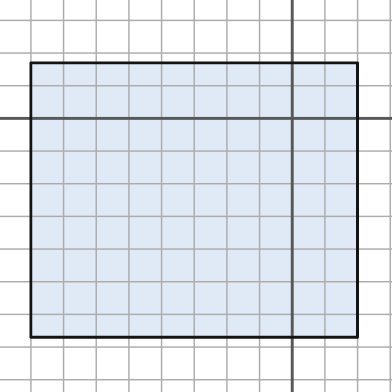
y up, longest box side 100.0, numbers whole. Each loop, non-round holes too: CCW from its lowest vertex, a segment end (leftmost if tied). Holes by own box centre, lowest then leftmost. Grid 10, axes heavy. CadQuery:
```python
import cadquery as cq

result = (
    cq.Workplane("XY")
    .moveTo(-80.0, -67.0)
    .lineTo(20.0, -67.0)
    .lineTo(20.0, 17.0)
    .lineTo(-80.0, 17.0)
    .close()
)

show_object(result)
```